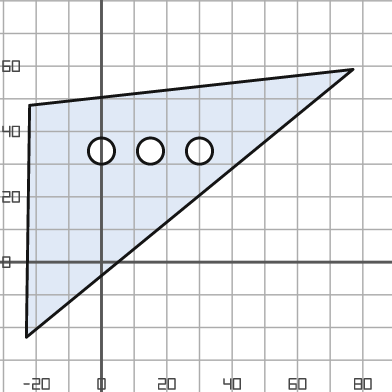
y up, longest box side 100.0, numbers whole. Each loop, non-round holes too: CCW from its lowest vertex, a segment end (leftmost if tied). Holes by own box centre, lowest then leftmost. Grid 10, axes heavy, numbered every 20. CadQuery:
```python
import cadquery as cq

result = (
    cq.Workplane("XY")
    .moveTo(-23.0, -23.0)
    .lineTo(77.0, 59.0)
    .lineTo(-22.0, 48.0)
    .close()
    .moveTo(0.0, 34.0)
    .circle(4.0)
    .moveTo(15.0, 34.0)
    .circle(4.0)
    .moveTo(30.0, 34.0)
    .circle(4.0)
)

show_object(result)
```